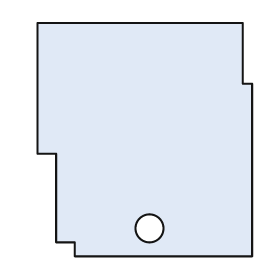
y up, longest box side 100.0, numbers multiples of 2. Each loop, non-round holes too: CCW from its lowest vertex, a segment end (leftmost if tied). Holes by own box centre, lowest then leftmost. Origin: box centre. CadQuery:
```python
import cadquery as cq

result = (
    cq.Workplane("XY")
    .moveTo(-30.0, -50.0)
    .lineTo(46.0, -50.0)
    .lineTo(46.0, 24.0)
    .lineTo(42.0, 24.0)
    .lineTo(42.0, 50.0)
    .lineTo(-46.0, 50.0)
    .lineTo(-46.0, -6.0)
    .lineTo(-38.0, -6.0)
    .lineTo(-38.0, -44.0)
    .lineTo(-30.0, -44.0)
    .close()
    .moveTo(2.0, -38.0)
    .circle(6.0)
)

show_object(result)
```